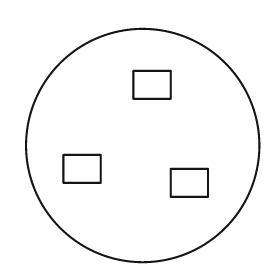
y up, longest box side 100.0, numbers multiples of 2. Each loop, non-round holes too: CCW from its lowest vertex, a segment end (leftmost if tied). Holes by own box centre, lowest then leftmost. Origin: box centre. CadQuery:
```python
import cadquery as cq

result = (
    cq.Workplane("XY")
    .moveTo(0.0, 0.0)
    .circle(50.0)
    .moveTo(12.0, -22.0)
    .lineTo(28.0, -22.0)
    .lineTo(28.0, -10.0)
    .lineTo(12.0, -10.0)
    .close()
    .moveTo(-34.0, -16.0)
    .lineTo(-18.0, -16.0)
    .lineTo(-18.0, -4.0)
    .lineTo(-34.0, -4.0)
    .close()
    .moveTo(-4.0, 20.0)
    .lineTo(12.0, 20.0)
    .lineTo(12.0, 32.0)
    .lineTo(-4.0, 32.0)
    .close()
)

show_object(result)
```